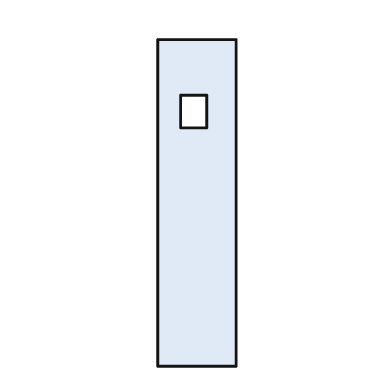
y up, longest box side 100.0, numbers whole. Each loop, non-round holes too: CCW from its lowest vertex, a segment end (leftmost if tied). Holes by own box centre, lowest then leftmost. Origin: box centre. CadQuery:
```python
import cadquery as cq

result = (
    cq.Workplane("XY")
    .moveTo(-12.0, -50.0)
    .lineTo(12.0, -50.0)
    .lineTo(12.0, 50.0)
    .lineTo(-12.0, 50.0)
    .close()
    .moveTo(-5.0, 23.0)
    .lineTo(3.0, 23.0)
    .lineTo(3.0, 33.0)
    .lineTo(-5.0, 33.0)
    .close()
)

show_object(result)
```